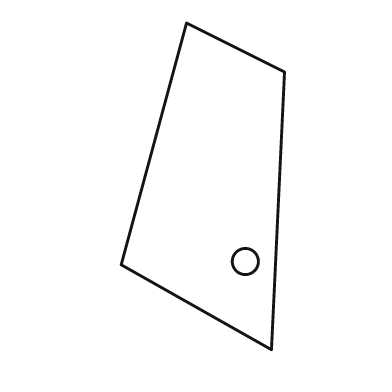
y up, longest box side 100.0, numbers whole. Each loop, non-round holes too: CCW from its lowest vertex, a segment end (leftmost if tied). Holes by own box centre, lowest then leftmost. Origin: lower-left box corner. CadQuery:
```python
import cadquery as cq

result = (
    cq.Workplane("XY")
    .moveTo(46.0, 0.0)
    .lineTo(50.0, 85.0)
    .lineTo(20.0, 100.0)
    .lineTo(0.0, 26.0)
    .close()
    .moveTo(38.0, 27.0)
    .circle(4.0)
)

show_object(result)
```